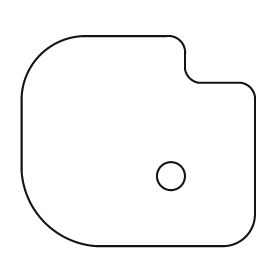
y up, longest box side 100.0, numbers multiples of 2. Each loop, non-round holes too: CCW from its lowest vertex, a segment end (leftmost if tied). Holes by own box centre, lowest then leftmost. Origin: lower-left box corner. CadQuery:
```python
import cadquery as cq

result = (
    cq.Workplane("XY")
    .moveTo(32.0, 0.0)
    .lineTo(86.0, 0.0)
    .threePointArc((96.0, 4.0), (100.0, 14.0))
    .lineTo(100.0, 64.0)
    .threePointArc((98.0, 68.0), (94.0, 70.0))
    .lineTo(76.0, 70.0)
    .threePointArc((72.0, 72.0), (70.0, 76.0))
    .lineTo(70.0, 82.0)
    .threePointArc((68.0, 88.0), (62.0, 90.0))
    .lineTo(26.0, 90.0)
    .threePointArc((8.0, 82.0), (0.0, 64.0))
    .lineTo(0.0, 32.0)
    .threePointArc((10.0, 10.0), (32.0, 0.0))
    .close()
    .moveTo(64.0, 30.0)
    .circle(6.0)
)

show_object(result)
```